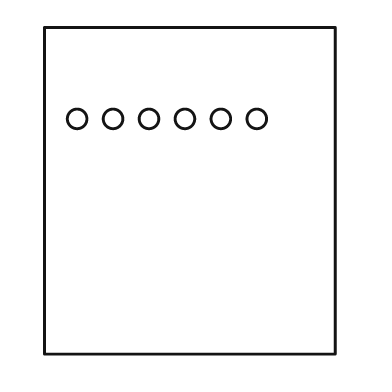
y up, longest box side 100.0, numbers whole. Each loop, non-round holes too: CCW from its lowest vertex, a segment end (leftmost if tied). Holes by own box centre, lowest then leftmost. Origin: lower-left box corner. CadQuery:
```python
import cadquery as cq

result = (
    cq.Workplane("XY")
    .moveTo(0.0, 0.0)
    .lineTo(89.0, 0.0)
    .lineTo(89.0, 100.0)
    .lineTo(0.0, 100.0)
    .close()
    .moveTo(10.0, 72.0)
    .circle(3.0)
    .moveTo(21.0, 72.0)
    .circle(3.0)
    .moveTo(32.0, 72.0)
    .circle(3.0)
    .moveTo(43.0, 72.0)
    .circle(3.0)
    .moveTo(54.0, 72.0)
    .circle(3.0)
    .moveTo(65.0, 72.0)
    .circle(3.0)
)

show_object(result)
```